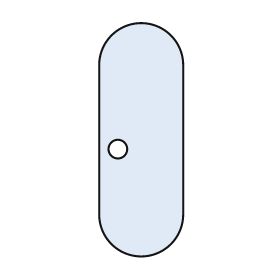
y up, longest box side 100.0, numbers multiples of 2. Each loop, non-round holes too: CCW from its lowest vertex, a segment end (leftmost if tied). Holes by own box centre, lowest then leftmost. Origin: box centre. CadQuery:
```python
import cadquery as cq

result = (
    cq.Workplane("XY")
    .moveTo(-18.0, -32.0)
    .threePointArc((0.0, -50.0), (18.0, -32.0))
    .lineTo(18.0, 32.0)
    .threePointArc((0.0, 50.0), (-18.0, 32.0))
    .close()
    .moveTo(-10.0, -4.0)
    .circle(4.0)
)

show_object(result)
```